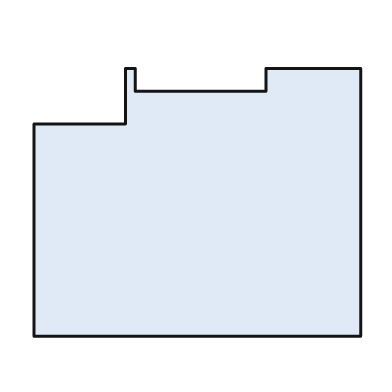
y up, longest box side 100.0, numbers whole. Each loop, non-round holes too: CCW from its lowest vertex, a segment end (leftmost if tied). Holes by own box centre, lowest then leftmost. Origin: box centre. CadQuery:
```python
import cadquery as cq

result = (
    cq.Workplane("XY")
    .moveTo(-50.0, -41.0)
    .lineTo(50.0, -41.0)
    .lineTo(50.0, 41.0)
    .lineTo(21.0, 41.0)
    .lineTo(21.0, 34.0)
    .lineTo(-19.0, 34.0)
    .lineTo(-19.0, 41.0)
    .lineTo(-22.0, 41.0)
    .lineTo(-22.0, 24.0)
    .lineTo(-50.0, 24.0)
    .close()
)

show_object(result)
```